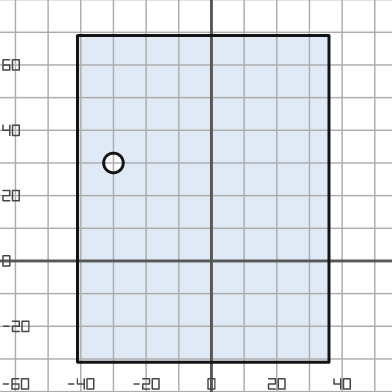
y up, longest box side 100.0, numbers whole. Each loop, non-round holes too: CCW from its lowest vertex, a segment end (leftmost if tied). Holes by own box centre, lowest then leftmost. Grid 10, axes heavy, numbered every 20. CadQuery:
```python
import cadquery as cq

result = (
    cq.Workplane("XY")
    .moveTo(-41.0, -31.0)
    .lineTo(36.0, -31.0)
    .lineTo(36.0, 69.0)
    .lineTo(-41.0, 69.0)
    .close()
    .moveTo(-30.0, 30.0)
    .circle(3.0)
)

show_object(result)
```